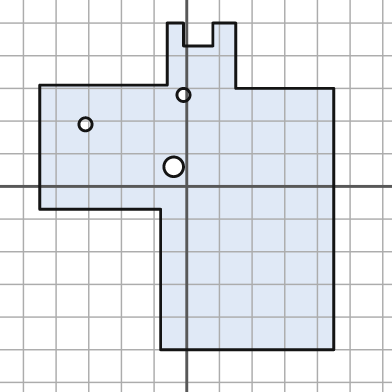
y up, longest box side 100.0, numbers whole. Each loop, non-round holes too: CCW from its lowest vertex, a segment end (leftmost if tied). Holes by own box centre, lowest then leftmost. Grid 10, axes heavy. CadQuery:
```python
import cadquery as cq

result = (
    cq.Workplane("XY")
    .moveTo(-8.0, -50.0)
    .lineTo(45.0, -50.0)
    .lineTo(45.0, 30.0)
    .lineTo(15.0, 30.0)
    .lineTo(15.0, 50.0)
    .lineTo(8.0, 50.0)
    .lineTo(8.0, 43.0)
    .lineTo(-1.0, 43.0)
    .lineTo(-1.0, 50.0)
    .lineTo(-6.0, 50.0)
    .lineTo(-6.0, 31.0)
    .lineTo(-45.0, 31.0)
    .lineTo(-45.0, -7.0)
    .lineTo(-8.0, -7.0)
    .close()
    .moveTo(-4.0, 6.0)
    .circle(3.0)
    .moveTo(-31.0, 19.0)
    .circle(2.0)
    .moveTo(-1.0, 28.0)
    .circle(2.0)
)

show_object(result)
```